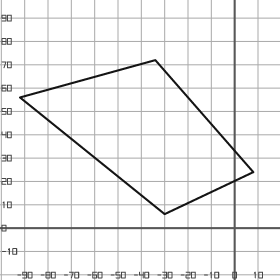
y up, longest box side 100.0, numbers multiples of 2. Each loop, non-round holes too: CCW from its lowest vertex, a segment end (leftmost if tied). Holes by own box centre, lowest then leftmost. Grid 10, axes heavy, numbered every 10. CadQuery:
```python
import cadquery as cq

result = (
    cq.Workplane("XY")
    .moveTo(-30.0, 6.0)
    .lineTo(8.0, 24.0)
    .lineTo(-34.0, 72.0)
    .lineTo(-92.0, 56.0)
    .close()
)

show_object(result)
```